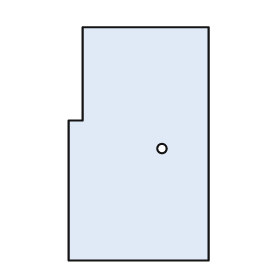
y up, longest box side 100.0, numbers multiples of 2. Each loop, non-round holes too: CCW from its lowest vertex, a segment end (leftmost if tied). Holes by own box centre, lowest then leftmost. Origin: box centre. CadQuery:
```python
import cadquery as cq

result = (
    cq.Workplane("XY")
    .moveTo(-30.0, -50.0)
    .lineTo(30.0, -50.0)
    .lineTo(30.0, 50.0)
    .lineTo(-24.0, 50.0)
    .lineTo(-24.0, 10.0)
    .lineTo(-30.0, 10.0)
    .close()
    .moveTo(10.0, -2.0)
    .circle(2.0)
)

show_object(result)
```